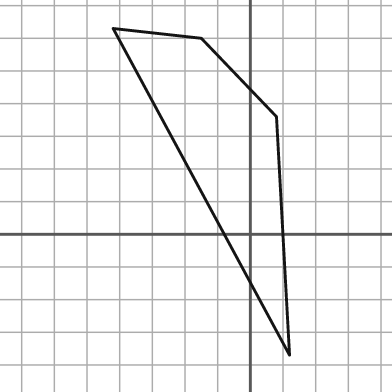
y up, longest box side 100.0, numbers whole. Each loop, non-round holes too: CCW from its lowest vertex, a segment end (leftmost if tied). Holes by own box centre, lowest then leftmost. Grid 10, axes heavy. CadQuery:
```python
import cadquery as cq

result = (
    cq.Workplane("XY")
    .moveTo(12.0, -37.0)
    .lineTo(8.0, 36.0)
    .lineTo(-15.0, 60.0)
    .lineTo(-42.0, 63.0)
    .close()
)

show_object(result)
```